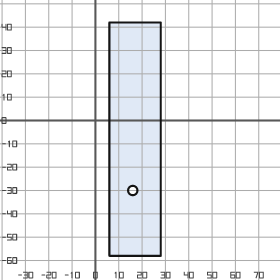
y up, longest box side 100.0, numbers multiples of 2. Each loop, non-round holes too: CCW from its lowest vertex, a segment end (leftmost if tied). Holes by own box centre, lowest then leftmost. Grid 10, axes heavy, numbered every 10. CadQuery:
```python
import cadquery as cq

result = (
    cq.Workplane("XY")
    .moveTo(6.0, -58.0)
    .lineTo(28.0, -58.0)
    .lineTo(28.0, 42.0)
    .lineTo(6.0, 42.0)
    .close()
    .moveTo(16.0, -30.0)
    .circle(2.0)
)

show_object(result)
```